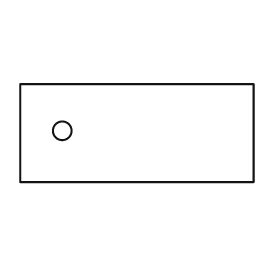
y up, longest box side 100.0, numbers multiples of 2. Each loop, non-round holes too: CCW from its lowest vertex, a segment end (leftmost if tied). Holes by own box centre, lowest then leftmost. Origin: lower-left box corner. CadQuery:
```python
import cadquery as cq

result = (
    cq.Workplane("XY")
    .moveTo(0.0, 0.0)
    .lineTo(100.0, 0.0)
    .lineTo(100.0, 42.0)
    .lineTo(0.0, 42.0)
    .close()
    .moveTo(18.0, 22.0)
    .circle(4.0)
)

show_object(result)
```